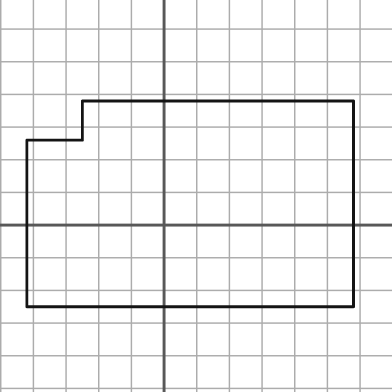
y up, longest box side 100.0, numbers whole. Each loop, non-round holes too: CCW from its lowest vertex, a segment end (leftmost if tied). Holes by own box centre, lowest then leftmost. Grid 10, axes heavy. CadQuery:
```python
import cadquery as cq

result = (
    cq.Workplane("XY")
    .moveTo(-42.0, -25.0)
    .lineTo(58.0, -25.0)
    .lineTo(58.0, 38.0)
    .lineTo(-25.0, 38.0)
    .lineTo(-25.0, 26.0)
    .lineTo(-42.0, 26.0)
    .close()
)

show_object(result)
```